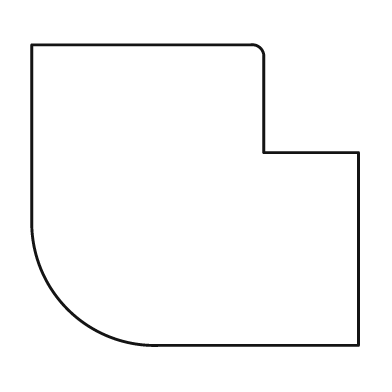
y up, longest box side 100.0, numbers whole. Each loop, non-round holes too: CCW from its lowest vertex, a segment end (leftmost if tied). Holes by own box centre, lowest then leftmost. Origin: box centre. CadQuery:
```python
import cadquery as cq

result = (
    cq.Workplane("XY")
    .moveTo(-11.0, -46.0)
    .lineTo(50.0, -46.0)
    .lineTo(50.0, 13.0)
    .lineTo(21.0, 13.0)
    .lineTo(21.0, 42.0)
    .threePointArc((20.0, 45.0), (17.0, 46.0))
    .lineTo(-50.0, 46.0)
    .lineTo(-50.0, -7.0)
    .threePointArc((-39.0, -35.0), (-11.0, -46.0))
    .close()
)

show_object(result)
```